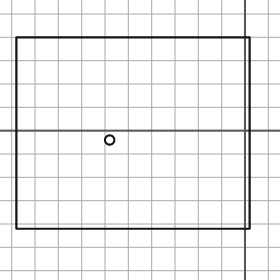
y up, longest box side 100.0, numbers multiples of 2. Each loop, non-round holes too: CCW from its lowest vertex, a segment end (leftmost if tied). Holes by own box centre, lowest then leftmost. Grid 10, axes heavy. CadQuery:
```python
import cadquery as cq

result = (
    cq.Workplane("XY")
    .moveTo(-98.0, -42.0)
    .lineTo(2.0, -42.0)
    .lineTo(2.0, 40.0)
    .lineTo(-98.0, 40.0)
    .close()
    .moveTo(-58.0, -4.0)
    .circle(2.0)
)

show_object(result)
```